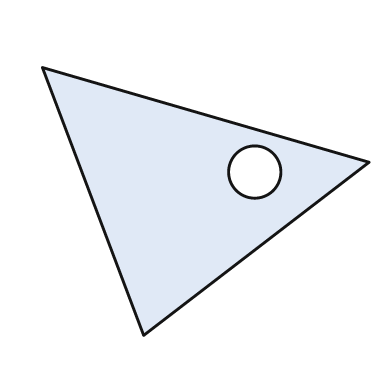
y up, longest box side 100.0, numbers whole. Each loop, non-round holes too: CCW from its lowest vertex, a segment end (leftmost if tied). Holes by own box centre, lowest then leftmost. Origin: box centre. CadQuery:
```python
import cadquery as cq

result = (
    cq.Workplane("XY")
    .moveTo(-19.0, -41.0)
    .lineTo(50.0, 12.0)
    .lineTo(-50.0, 41.0)
    .close()
    .moveTo(15.0, 9.0)
    .circle(8.0)
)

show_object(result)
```